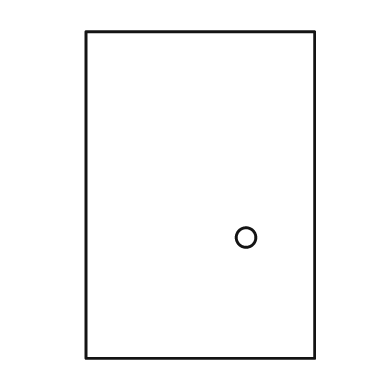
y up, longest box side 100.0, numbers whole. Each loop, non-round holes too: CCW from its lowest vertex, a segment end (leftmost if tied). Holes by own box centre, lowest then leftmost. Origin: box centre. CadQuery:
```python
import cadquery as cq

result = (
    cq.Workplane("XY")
    .moveTo(-35.0, -50.0)
    .lineTo(35.0, -50.0)
    .lineTo(35.0, 50.0)
    .lineTo(-35.0, 50.0)
    .close()
    .moveTo(14.0, -13.0)
    .circle(3.0)
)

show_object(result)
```